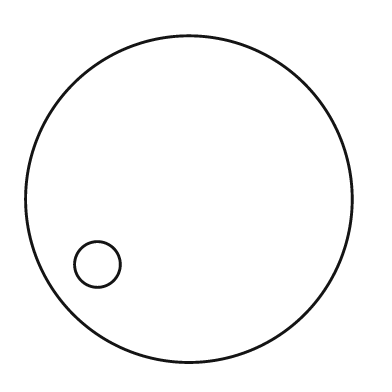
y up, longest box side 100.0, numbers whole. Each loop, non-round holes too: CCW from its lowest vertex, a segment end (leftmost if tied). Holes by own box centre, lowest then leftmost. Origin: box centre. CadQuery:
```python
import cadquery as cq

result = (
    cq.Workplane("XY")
    .moveTo(0.0, 0.0)
    .circle(50.0)
    .moveTo(-28.0, -20.0)
    .circle(7.0)
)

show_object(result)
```